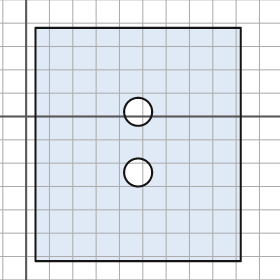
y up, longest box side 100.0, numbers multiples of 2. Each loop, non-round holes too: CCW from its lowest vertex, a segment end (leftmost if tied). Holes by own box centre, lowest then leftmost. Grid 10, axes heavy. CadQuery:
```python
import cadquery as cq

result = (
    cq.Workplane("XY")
    .moveTo(4.0, -62.0)
    .lineTo(92.0, -62.0)
    .lineTo(92.0, 38.0)
    .lineTo(4.0, 38.0)
    .close()
    .moveTo(48.0, -24.0)
    .circle(6.0)
    .moveTo(48.0, 2.0)
    .circle(6.0)
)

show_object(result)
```